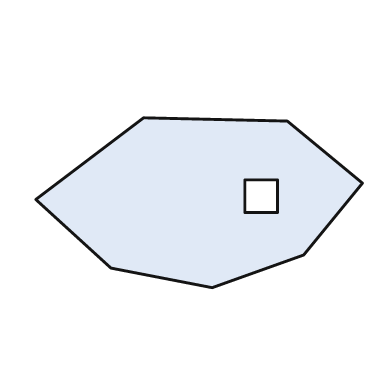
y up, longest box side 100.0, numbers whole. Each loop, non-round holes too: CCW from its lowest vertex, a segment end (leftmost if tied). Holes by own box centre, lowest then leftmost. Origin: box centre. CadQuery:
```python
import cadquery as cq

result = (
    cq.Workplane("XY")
    .moveTo(4.0, -26.0)
    .lineTo(32.0, -16.0)
    .lineTo(50.0, 6.0)
    .lineTo(27.0, 25.0)
    .lineTo(-17.0, 26.0)
    .lineTo(-50.0, 1.0)
    .lineTo(-27.0, -20.0)
    .close()
    .moveTo(14.0, -3.0)
    .lineTo(24.0, -3.0)
    .lineTo(24.0, 7.0)
    .lineTo(14.0, 7.0)
    .close()
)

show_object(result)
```